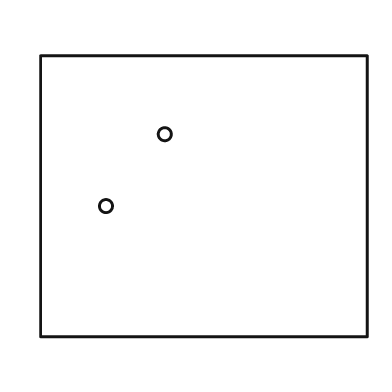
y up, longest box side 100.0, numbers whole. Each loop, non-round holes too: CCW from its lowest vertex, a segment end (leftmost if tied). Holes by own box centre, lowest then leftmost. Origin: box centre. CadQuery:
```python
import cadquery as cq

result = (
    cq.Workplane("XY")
    .moveTo(-50.0, -43.0)
    .lineTo(50.0, -43.0)
    .lineTo(50.0, 43.0)
    .lineTo(-50.0, 43.0)
    .close()
    .moveTo(-30.0, -3.0)
    .circle(2.0)
    .moveTo(-12.0, 19.0)
    .circle(2.0)
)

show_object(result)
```